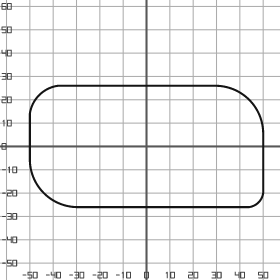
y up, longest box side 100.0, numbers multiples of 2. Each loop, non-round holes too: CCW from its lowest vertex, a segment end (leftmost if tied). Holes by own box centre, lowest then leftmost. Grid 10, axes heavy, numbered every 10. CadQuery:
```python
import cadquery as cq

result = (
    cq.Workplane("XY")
    .moveTo(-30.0, -26.0)
    .lineTo(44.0, -26.0)
    .threePointArc((48.0, -24.0), (50.0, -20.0))
    .lineTo(50.0, 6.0)
    .threePointArc((44.0, 20.0), (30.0, 26.0))
    .lineTo(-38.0, 26.0)
    .threePointArc((-46.0, 22.0), (-50.0, 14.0))
    .lineTo(-50.0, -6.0)
    .threePointArc((-44.0, -20.0), (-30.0, -26.0))
    .close()
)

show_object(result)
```